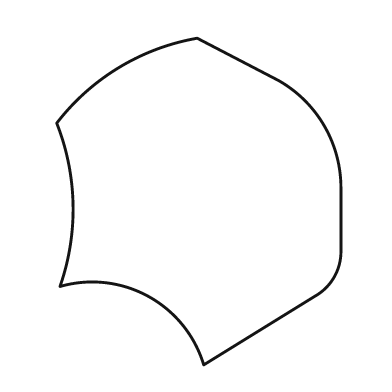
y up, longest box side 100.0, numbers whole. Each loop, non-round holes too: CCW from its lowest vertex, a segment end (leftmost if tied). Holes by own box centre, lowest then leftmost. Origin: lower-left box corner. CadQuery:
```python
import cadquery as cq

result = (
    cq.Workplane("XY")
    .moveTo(45.0, 0.0)
    .lineTo(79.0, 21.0)
    .threePointArc((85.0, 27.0), (87.0, 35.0))
    .lineTo(87.0, 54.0)
    .threePointArc((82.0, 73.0), (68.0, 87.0))
    .lineTo(43.0, 100.0)
    .threePointArc((19.0, 91.0), (0.0, 74.0))
    .threePointArc((5.0, 49.0), (1.0, 24.0))
    .threePointArc((28.0, 21.0), (45.0, 0.0))
    .close()
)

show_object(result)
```